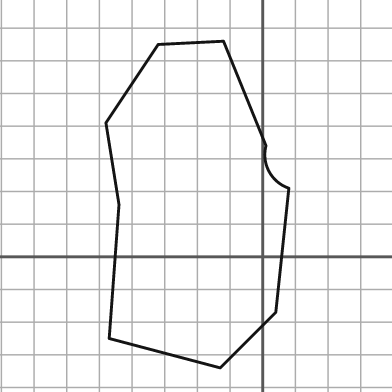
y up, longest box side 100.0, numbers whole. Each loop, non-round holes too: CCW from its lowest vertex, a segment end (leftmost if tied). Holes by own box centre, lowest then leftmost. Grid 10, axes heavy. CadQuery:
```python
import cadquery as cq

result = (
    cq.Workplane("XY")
    .moveTo(-13.0, -34.0)
    .lineTo(4.0, -17.0)
    .lineTo(8.0, 21.0)
    .threePointArc((2.0, 26.0), (1.0, 34.0))
    .lineTo(-12.0, 66.0)
    .lineTo(-32.0, 65.0)
    .lineTo(-48.0, 41.0)
    .lineTo(-44.0, 16.0)
    .lineTo(-47.0, -25.0)
    .close()
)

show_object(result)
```